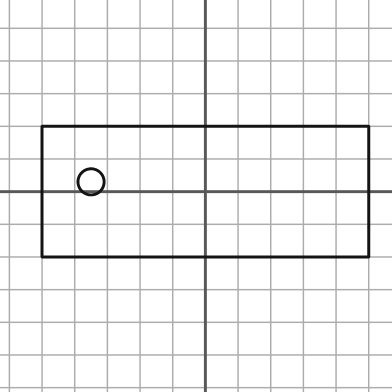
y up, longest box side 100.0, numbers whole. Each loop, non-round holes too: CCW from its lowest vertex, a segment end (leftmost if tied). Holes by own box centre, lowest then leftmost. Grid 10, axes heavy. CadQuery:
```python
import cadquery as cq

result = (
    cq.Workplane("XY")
    .moveTo(-50.0, -20.0)
    .lineTo(50.0, -20.0)
    .lineTo(50.0, 20.0)
    .lineTo(-50.0, 20.0)
    .close()
    .moveTo(-35.0, 3.0)
    .circle(4.0)
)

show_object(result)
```